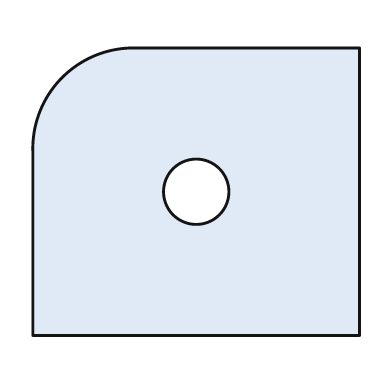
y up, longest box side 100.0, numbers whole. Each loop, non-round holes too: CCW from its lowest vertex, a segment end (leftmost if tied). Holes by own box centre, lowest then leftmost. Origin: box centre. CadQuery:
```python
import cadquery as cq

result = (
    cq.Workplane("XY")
    .moveTo(-50.0, -44.0)
    .lineTo(50.0, -44.0)
    .lineTo(50.0, 44.0)
    .lineTo(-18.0, 44.0)
    .threePointArc((-41.0, 35.0), (-50.0, 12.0))
    .close()
    .moveTo(0.0, 0.0)
    .circle(10.0)
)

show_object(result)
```